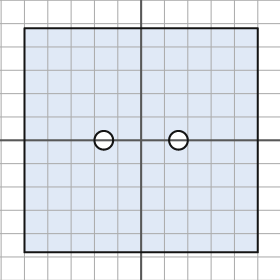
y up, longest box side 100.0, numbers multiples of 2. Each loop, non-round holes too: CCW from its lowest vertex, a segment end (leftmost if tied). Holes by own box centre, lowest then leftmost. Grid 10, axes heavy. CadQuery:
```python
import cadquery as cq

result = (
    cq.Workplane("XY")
    .moveTo(-50.0, -48.0)
    .lineTo(50.0, -48.0)
    .lineTo(50.0, 48.0)
    .lineTo(-50.0, 48.0)
    .close()
    .moveTo(-16.0, 0.0)
    .circle(4.0)
    .moveTo(16.0, 0.0)
    .circle(4.0)
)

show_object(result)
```